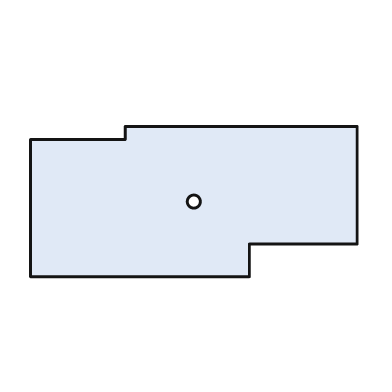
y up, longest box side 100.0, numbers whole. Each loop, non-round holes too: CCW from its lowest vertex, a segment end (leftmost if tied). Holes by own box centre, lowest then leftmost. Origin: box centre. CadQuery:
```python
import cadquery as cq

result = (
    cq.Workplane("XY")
    .moveTo(-50.0, -23.0)
    .lineTo(17.0, -23.0)
    .lineTo(17.0, -13.0)
    .lineTo(50.0, -13.0)
    .lineTo(50.0, 23.0)
    .lineTo(-21.0, 23.0)
    .lineTo(-21.0, 19.0)
    .lineTo(-50.0, 19.0)
    .close()
    .moveTo(0.0, 0.0)
    .circle(2.0)
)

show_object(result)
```